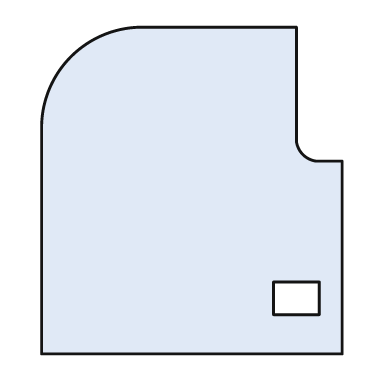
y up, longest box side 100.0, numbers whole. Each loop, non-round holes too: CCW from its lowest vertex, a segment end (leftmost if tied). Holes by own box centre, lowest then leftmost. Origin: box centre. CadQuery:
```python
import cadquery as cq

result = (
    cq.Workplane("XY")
    .moveTo(-46.0, -50.0)
    .lineTo(46.0, -50.0)
    .lineTo(46.0, 9.0)
    .lineTo(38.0, 9.0)
    .threePointArc((34.0, 11.0), (32.0, 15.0))
    .lineTo(32.0, 50.0)
    .lineTo(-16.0, 50.0)
    .threePointArc((-37.0, 41.0), (-46.0, 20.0))
    .close()
    .moveTo(25.0, -38.0)
    .lineTo(39.0, -38.0)
    .lineTo(39.0, -28.0)
    .lineTo(25.0, -28.0)
    .close()
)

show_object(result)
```